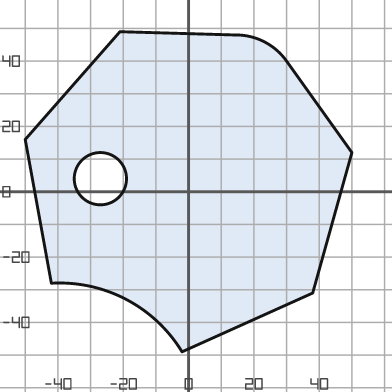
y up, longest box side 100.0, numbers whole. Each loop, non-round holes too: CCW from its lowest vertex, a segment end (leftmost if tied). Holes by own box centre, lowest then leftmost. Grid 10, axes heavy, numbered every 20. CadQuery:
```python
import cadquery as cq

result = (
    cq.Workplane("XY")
    .moveTo(-2.0, -49.0)
    .lineTo(38.0, -31.0)
    .lineTo(50.0, 12.0)
    .lineTo(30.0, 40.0)
    .threePointArc((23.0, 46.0), (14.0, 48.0))
    .lineTo(-21.0, 49.0)
    .lineTo(-50.0, 16.0)
    .lineTo(-42.0, -28.0)
    .threePointArc((-19.0, -33.0), (-2.0, -49.0))
    .close()
    .moveTo(-27.0, 4.0)
    .circle(8.0)
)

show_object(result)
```